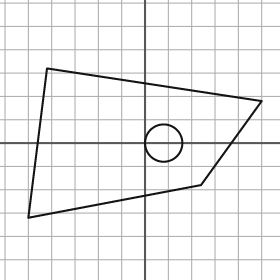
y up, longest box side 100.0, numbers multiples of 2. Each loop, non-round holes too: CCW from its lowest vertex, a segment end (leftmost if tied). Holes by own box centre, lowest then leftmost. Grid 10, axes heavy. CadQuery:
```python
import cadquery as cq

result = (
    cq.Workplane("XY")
    .moveTo(-50.0, -32.0)
    .lineTo(24.0, -18.0)
    .lineTo(50.0, 18.0)
    .lineTo(-42.0, 32.0)
    .close()
    .moveTo(8.0, 0.0)
    .circle(8.0)
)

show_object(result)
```